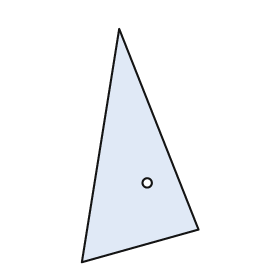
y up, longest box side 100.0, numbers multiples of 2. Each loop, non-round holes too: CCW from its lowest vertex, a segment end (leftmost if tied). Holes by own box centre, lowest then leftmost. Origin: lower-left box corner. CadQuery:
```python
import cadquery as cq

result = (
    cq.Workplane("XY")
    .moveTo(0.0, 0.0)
    .lineTo(50.0, 14.0)
    .lineTo(16.0, 100.0)
    .close()
    .moveTo(28.0, 34.0)
    .circle(2.0)
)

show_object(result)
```